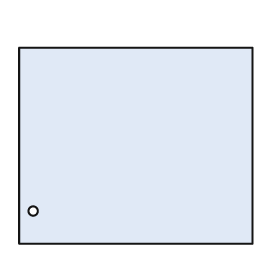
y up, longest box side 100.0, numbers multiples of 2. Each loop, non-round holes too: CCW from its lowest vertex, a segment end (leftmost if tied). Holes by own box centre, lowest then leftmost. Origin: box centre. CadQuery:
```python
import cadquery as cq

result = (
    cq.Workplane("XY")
    .moveTo(-50.0, -42.0)
    .lineTo(50.0, -42.0)
    .lineTo(50.0, 42.0)
    .lineTo(-50.0, 42.0)
    .close()
    .moveTo(-44.0, -28.0)
    .circle(2.0)
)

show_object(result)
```